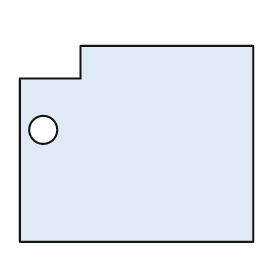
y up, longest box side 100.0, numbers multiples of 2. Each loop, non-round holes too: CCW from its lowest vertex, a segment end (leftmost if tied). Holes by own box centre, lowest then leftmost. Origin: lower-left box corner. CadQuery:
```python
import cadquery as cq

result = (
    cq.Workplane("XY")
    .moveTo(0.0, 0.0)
    .lineTo(100.0, 0.0)
    .lineTo(100.0, 84.0)
    .lineTo(26.0, 84.0)
    .lineTo(26.0, 70.0)
    .lineTo(0.0, 70.0)
    .close()
    .moveTo(10.0, 48.0)
    .circle(6.0)
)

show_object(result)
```